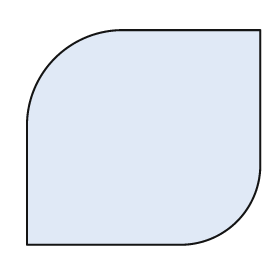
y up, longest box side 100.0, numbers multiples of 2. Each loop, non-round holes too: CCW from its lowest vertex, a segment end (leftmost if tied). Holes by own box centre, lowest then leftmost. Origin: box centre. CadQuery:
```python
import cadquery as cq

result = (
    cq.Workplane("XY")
    .moveTo(-50.0, -46.0)
    .lineTo(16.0, -46.0)
    .threePointArc((40.0, -36.0), (50.0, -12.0))
    .lineTo(50.0, 46.0)
    .lineTo(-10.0, 46.0)
    .threePointArc((-38.0, 34.0), (-50.0, 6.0))
    .close()
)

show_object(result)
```